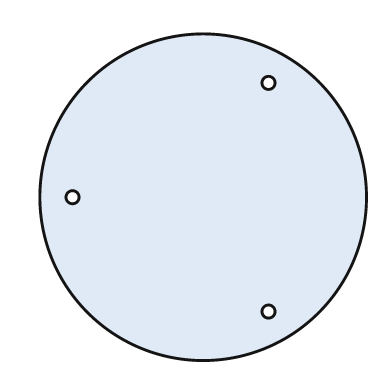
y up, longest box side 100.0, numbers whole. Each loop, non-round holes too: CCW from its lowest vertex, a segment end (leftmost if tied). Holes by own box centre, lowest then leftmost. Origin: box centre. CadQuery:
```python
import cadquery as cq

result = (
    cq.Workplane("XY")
    .moveTo(0.0, 0.0)
    .circle(50.0)
    .moveTo(20.0, -35.0)
    .circle(2.0)
    .moveTo(-40.0, 0.0)
    .circle(2.0)
    .moveTo(20.0, 35.0)
    .circle(2.0)
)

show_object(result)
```